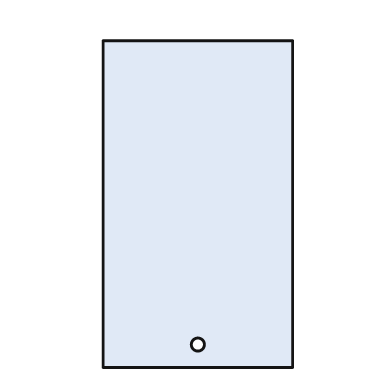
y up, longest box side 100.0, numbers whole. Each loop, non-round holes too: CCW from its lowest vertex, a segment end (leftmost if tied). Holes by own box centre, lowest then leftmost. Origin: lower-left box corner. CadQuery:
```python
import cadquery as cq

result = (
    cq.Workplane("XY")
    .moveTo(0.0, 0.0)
    .lineTo(58.0, 0.0)
    .lineTo(58.0, 100.0)
    .lineTo(0.0, 100.0)
    .close()
    .moveTo(29.0, 7.0)
    .circle(2.0)
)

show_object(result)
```